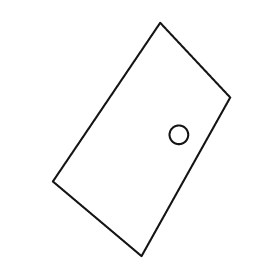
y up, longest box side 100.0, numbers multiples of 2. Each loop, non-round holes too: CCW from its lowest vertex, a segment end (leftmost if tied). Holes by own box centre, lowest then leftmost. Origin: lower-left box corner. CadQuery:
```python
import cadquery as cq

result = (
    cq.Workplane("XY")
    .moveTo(38.0, 0.0)
    .lineTo(76.0, 68.0)
    .lineTo(46.0, 100.0)
    .lineTo(0.0, 32.0)
    .close()
    .moveTo(54.0, 52.0)
    .circle(4.0)
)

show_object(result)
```